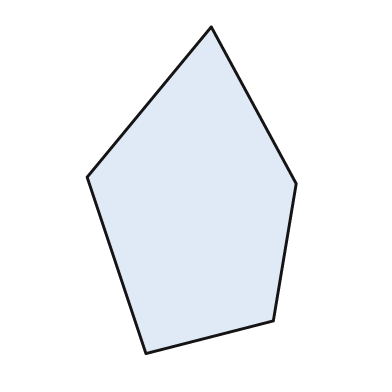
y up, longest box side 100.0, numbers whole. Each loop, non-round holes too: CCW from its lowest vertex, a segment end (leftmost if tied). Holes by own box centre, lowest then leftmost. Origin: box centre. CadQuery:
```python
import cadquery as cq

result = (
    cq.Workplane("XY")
    .moveTo(-14.0, -50.0)
    .lineTo(25.0, -40.0)
    .lineTo(32.0, 2.0)
    .lineTo(6.0, 50.0)
    .lineTo(-32.0, 4.0)
    .close()
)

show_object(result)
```